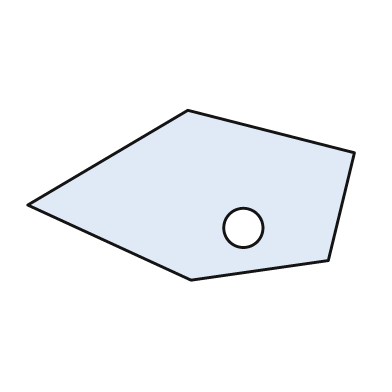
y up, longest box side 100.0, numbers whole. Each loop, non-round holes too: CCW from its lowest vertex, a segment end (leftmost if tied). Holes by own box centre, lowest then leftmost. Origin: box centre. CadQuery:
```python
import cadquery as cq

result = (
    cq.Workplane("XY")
    .moveTo(0.0, -26.0)
    .lineTo(42.0, -20.0)
    .lineTo(50.0, 13.0)
    .lineTo(-1.0, 26.0)
    .lineTo(-50.0, -3.0)
    .close()
    .moveTo(16.0, -10.0)
    .circle(6.0)
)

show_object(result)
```